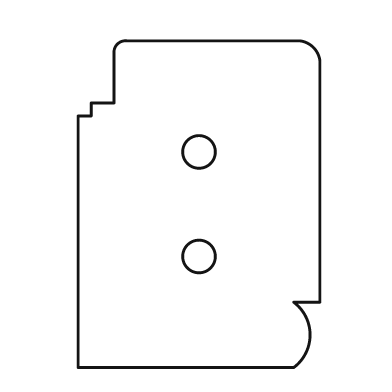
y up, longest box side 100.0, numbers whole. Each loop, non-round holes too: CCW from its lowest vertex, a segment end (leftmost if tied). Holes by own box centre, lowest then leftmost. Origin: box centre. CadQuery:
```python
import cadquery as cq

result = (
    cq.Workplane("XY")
    .moveTo(-37.0, -50.0)
    .lineTo(29.0, -50.0)
    .threePointArc((34.0, -40.0), (29.0, -30.0))
    .lineTo(37.0, -30.0)
    .lineTo(37.0, 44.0)
    .threePointArc((35.0, 48.0), (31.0, 50.0))
    .lineTo(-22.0, 50.0)
    .threePointArc((-25.0, 49.0), (-26.0, 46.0))
    .lineTo(-26.0, 31.0)
    .lineTo(-33.0, 31.0)
    .lineTo(-33.0, 27.0)
    .lineTo(-37.0, 27.0)
    .close()
    .moveTo(0.0, -16.0)
    .circle(5.0)
    .moveTo(0.0, 16.0)
    .circle(5.0)
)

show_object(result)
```